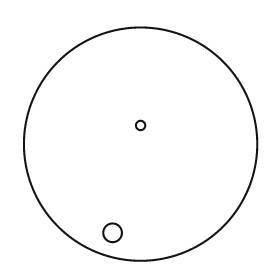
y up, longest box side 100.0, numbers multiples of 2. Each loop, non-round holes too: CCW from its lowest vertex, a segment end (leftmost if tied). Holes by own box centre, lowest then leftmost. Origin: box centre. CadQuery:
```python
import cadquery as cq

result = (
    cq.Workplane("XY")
    .moveTo(0.0, 0.0)
    .circle(50.0)
    .moveTo(-12.0, -38.0)
    .circle(4.0)
    .moveTo(0.0, 8.0)
    .circle(2.0)
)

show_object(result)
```